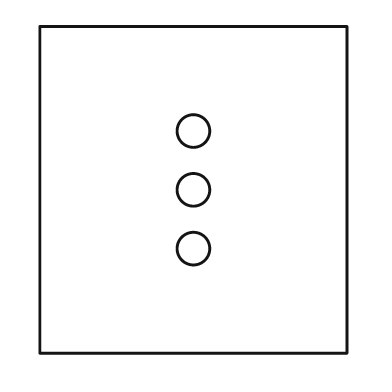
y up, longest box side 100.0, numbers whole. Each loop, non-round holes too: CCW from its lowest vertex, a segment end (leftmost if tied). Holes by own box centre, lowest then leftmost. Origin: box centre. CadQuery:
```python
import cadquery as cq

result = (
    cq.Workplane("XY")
    .moveTo(-47.0, -50.0)
    .lineTo(47.0, -50.0)
    .lineTo(47.0, 50.0)
    .lineTo(-47.0, 50.0)
    .close()
    .moveTo(0.0, -18.0)
    .circle(5.0)
    .moveTo(0.0, 0.0)
    .circle(5.0)
    .moveTo(0.0, 18.0)
    .circle(5.0)
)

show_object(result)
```